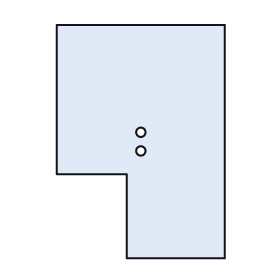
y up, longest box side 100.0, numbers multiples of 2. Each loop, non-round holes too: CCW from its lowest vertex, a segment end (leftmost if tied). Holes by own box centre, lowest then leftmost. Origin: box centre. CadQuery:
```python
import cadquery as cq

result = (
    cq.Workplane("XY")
    .moveTo(-6.0, -50.0)
    .lineTo(36.0, -50.0)
    .lineTo(36.0, 50.0)
    .lineTo(-36.0, 50.0)
    .lineTo(-36.0, -14.0)
    .lineTo(-6.0, -14.0)
    .close()
    .moveTo(0.0, -4.0)
    .circle(2.0)
    .moveTo(0.0, 4.0)
    .circle(2.0)
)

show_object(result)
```